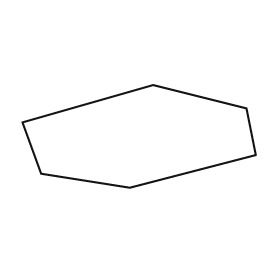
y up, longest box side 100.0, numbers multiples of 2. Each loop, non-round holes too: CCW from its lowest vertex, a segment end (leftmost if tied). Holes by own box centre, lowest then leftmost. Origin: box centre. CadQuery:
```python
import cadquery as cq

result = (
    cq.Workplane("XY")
    .moveTo(-4.0, -22.0)
    .lineTo(50.0, -8.0)
    .lineTo(46.0, 12.0)
    .lineTo(6.0, 22.0)
    .lineTo(-50.0, 6.0)
    .lineTo(-42.0, -16.0)
    .close()
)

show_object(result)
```